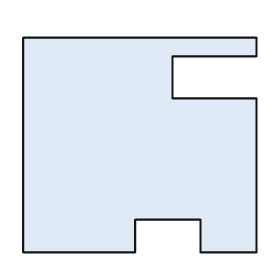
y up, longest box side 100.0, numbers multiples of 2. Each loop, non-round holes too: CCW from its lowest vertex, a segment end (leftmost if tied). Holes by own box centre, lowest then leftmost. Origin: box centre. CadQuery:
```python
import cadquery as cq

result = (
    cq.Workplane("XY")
    .moveTo(-50.0, -46.0)
    .lineTo(-2.0, -46.0)
    .lineTo(-2.0, -32.0)
    .lineTo(26.0, -32.0)
    .lineTo(26.0, -46.0)
    .lineTo(50.0, -46.0)
    .lineTo(50.0, 20.0)
    .lineTo(14.0, 20.0)
    .lineTo(14.0, 38.0)
    .lineTo(50.0, 38.0)
    .lineTo(50.0, 46.0)
    .lineTo(-50.0, 46.0)
    .close()
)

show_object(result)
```